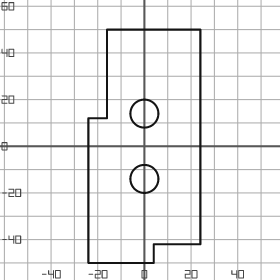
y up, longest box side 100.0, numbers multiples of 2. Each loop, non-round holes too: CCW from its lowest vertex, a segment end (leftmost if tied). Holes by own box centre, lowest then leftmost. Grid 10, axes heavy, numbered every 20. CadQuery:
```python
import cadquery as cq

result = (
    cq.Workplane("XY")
    .moveTo(-24.0, -50.0)
    .lineTo(4.0, -50.0)
    .lineTo(4.0, -42.0)
    .lineTo(24.0, -42.0)
    .lineTo(24.0, 50.0)
    .lineTo(-16.0, 50.0)
    .lineTo(-16.0, 12.0)
    .lineTo(-24.0, 12.0)
    .close()
    .moveTo(0.0, -14.0)
    .circle(6.0)
    .moveTo(0.0, 14.0)
    .circle(6.0)
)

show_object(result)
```